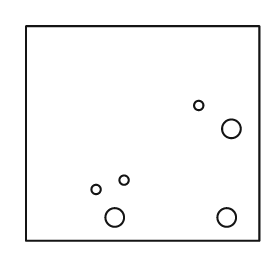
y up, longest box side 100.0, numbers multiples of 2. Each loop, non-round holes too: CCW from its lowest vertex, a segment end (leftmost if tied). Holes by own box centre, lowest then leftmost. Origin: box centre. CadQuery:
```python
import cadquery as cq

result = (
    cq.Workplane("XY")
    .moveTo(-50.0, -46.0)
    .lineTo(50.0, -46.0)
    .lineTo(50.0, 46.0)
    .lineTo(-50.0, 46.0)
    .close()
    .moveTo(-12.0, -36.0)
    .circle(4.0)
    .moveTo(36.0, -36.0)
    .circle(4.0)
    .moveTo(-20.0, -24.0)
    .circle(2.0)
    .moveTo(-8.0, -20.0)
    .circle(2.0)
    .moveTo(38.0, 2.0)
    .circle(4.0)
    .moveTo(24.0, 12.0)
    .circle(2.0)
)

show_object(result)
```